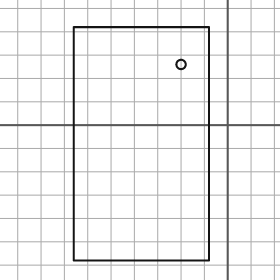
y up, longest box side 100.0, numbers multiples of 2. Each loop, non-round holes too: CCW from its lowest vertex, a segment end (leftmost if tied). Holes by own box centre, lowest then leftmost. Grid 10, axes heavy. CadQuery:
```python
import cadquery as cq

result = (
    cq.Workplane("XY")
    .moveTo(-66.0, -58.0)
    .lineTo(-8.0, -58.0)
    .lineTo(-8.0, 42.0)
    .lineTo(-66.0, 42.0)
    .close()
    .moveTo(-20.0, 26.0)
    .circle(2.0)
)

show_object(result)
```